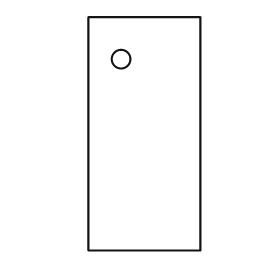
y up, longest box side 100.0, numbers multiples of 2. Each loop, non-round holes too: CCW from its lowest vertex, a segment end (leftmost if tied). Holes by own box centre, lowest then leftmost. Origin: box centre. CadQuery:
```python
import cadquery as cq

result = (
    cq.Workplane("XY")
    .moveTo(-24.0, -50.0)
    .lineTo(24.0, -50.0)
    .lineTo(24.0, 50.0)
    .lineTo(-24.0, 50.0)
    .close()
    .moveTo(-10.0, 32.0)
    .circle(4.0)
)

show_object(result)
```